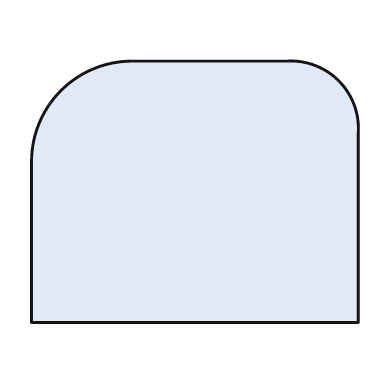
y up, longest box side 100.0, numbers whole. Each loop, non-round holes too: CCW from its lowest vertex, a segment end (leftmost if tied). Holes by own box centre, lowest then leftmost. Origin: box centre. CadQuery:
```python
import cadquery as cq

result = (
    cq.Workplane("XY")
    .moveTo(-50.0, -40.0)
    .lineTo(50.0, -40.0)
    .lineTo(50.0, 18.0)
    .threePointArc((44.0, 34.0), (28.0, 40.0))
    .lineTo(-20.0, 40.0)
    .threePointArc((-41.0, 31.0), (-50.0, 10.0))
    .close()
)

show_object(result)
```